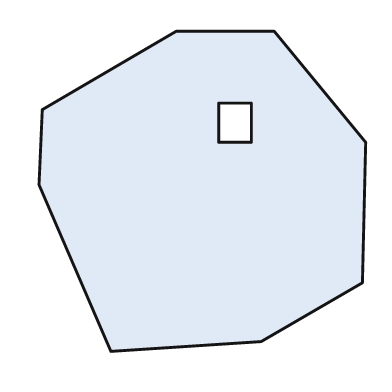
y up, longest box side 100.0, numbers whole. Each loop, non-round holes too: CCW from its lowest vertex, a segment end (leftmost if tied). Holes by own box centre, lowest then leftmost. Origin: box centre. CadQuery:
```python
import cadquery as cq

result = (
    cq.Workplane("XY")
    .moveTo(-28.0, -49.0)
    .lineTo(18.0, -46.0)
    .lineTo(49.0, -28.0)
    .lineTo(50.0, 15.0)
    .lineTo(22.0, 49.0)
    .lineTo(-8.0, 49.0)
    .lineTo(-49.0, 25.0)
    .lineTo(-50.0, 2.0)
    .close()
    .moveTo(5.0, 15.0)
    .lineTo(15.0, 15.0)
    .lineTo(15.0, 27.0)
    .lineTo(5.0, 27.0)
    .close()
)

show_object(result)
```